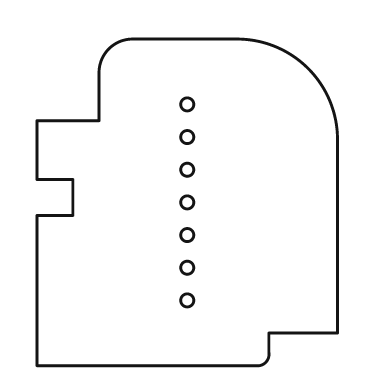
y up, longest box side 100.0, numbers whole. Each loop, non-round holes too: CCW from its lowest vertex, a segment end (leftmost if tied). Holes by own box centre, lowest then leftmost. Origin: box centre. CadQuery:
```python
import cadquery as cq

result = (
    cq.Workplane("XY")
    .moveTo(-46.0, -50.0)
    .lineTo(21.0, -50.0)
    .threePointArc((24.0, -49.0), (25.0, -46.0))
    .lineTo(25.0, -40.0)
    .lineTo(46.0, -40.0)
    .lineTo(46.0, 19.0)
    .threePointArc((37.0, 41.0), (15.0, 50.0))
    .lineTo(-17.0, 50.0)
    .threePointArc((-24.0, 47.0), (-27.0, 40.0))
    .lineTo(-27.0, 25.0)
    .lineTo(-46.0, 25.0)
    .lineTo(-46.0, 7.0)
    .lineTo(-35.0, 7.0)
    .lineTo(-35.0, -4.0)
    .lineTo(-46.0, -4.0)
    .close()
    .moveTo(0.0, -30.0)
    .circle(2.0)
    .moveTo(0.0, -20.0)
    .circle(2.0)
    .moveTo(0.0, -10.0)
    .circle(2.0)
    .moveTo(0.0, 0.0)
    .circle(2.0)
    .moveTo(0.0, 10.0)
    .circle(2.0)
    .moveTo(0.0, 20.0)
    .circle(2.0)
    .moveTo(0.0, 30.0)
    .circle(2.0)
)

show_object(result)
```